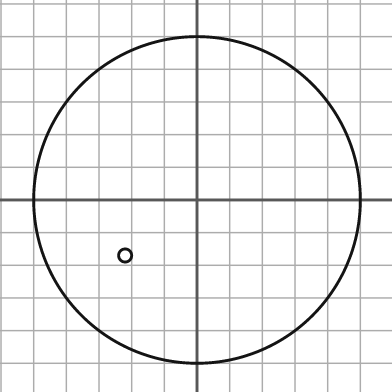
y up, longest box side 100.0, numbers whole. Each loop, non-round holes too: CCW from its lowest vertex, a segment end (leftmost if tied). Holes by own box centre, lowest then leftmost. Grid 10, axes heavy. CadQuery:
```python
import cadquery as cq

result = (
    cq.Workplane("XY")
    .moveTo(0.0, 0.0)
    .circle(50.0)
    .moveTo(-22.0, -17.0)
    .circle(2.0)
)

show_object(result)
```